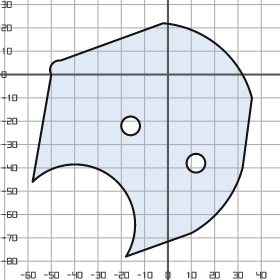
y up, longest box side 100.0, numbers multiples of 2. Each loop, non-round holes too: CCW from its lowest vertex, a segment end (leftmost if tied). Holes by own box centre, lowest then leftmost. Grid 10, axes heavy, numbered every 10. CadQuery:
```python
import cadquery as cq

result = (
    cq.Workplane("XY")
    .moveTo(-18.0, -78.0)
    .lineTo(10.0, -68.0)
    .threePointArc((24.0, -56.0), (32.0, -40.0))
    .lineTo(36.0, -10.0)
    .threePointArc((22.0, 12.0), (-2.0, 22.0))
    .lineTo(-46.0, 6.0)
    .threePointArc((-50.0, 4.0), (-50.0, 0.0))
    .lineTo(-58.0, -46.0)
    .threePointArc((-24.0, -44.0), (-18.0, -78.0))
    .close()
    .moveTo(12.0, -38.0)
    .circle(4.0)
    .moveTo(-16.0, -22.0)
    .circle(4.0)
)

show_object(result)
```